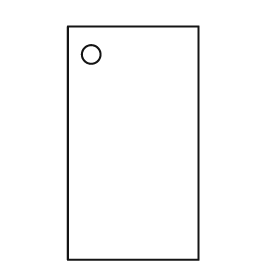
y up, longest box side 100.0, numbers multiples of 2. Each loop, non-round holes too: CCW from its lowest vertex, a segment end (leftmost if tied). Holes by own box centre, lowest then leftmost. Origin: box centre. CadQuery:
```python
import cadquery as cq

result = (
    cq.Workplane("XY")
    .moveTo(-28.0, -50.0)
    .lineTo(28.0, -50.0)
    .lineTo(28.0, 50.0)
    .lineTo(-28.0, 50.0)
    .close()
    .moveTo(-18.0, 38.0)
    .circle(4.0)
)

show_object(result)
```